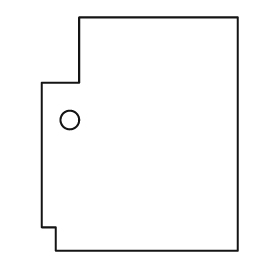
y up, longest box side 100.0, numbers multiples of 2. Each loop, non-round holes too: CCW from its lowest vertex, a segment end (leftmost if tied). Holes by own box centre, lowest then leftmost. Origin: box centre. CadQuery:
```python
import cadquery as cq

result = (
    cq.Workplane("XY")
    .moveTo(-36.0, -50.0)
    .lineTo(42.0, -50.0)
    .lineTo(42.0, 50.0)
    .lineTo(-26.0, 50.0)
    .lineTo(-26.0, 22.0)
    .lineTo(-42.0, 22.0)
    .lineTo(-42.0, -40.0)
    .lineTo(-36.0, -40.0)
    .close()
    .moveTo(-30.0, 6.0)
    .circle(4.0)
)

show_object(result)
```